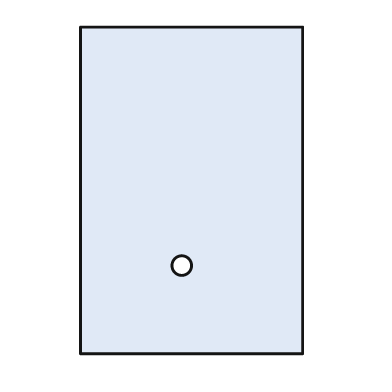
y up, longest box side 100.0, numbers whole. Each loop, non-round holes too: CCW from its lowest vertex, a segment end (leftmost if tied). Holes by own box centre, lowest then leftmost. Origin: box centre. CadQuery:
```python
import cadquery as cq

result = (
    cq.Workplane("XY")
    .moveTo(-34.0, -50.0)
    .lineTo(34.0, -50.0)
    .lineTo(34.0, 50.0)
    .lineTo(-34.0, 50.0)
    .close()
    .moveTo(-3.0, -23.0)
    .circle(3.0)
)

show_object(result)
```